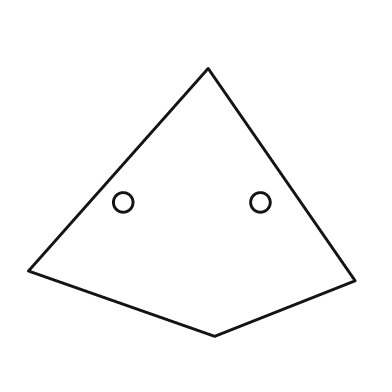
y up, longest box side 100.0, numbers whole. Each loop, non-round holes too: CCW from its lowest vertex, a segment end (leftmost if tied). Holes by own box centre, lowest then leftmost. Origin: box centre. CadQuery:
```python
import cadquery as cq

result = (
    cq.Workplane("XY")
    .moveTo(7.0, -41.0)
    .lineTo(50.0, -24.0)
    .lineTo(5.0, 41.0)
    .lineTo(-50.0, -21.0)
    .close()
    .moveTo(-21.0, 0.0)
    .circle(3.0)
    .moveTo(21.0, 0.0)
    .circle(3.0)
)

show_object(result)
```